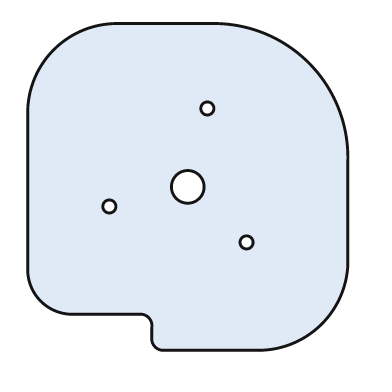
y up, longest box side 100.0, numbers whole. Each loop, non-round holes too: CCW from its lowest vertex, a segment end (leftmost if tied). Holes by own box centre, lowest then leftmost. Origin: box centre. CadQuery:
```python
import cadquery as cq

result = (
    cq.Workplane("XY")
    .moveTo(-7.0, -50.0)
    .lineTo(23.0, -50.0)
    .threePointArc((41.0, -42.0), (49.0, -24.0))
    .lineTo(49.0, 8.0)
    .threePointArc((37.0, 38.0), (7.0, 50.0))
    .lineTo(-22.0, 50.0)
    .threePointArc((-41.0, 42.0), (-49.0, 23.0))
    .lineTo(-49.0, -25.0)
    .threePointArc((-45.0, -35.0), (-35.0, -39.0))
    .lineTo(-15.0, -39.0)
    .threePointArc((-12.0, -40.0), (-11.0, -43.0))
    .lineTo(-11.0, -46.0)
    .threePointArc((-10.0, -49.0), (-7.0, -50.0))
    .close()
    .moveTo(18.0, -17.0)
    .circle(2.0)
    .moveTo(-24.0, -6.0)
    .circle(2.0)
    .moveTo(0.0, 0.0)
    .circle(5.0)
    .moveTo(6.0, 24.0)
    .circle(2.0)
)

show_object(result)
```